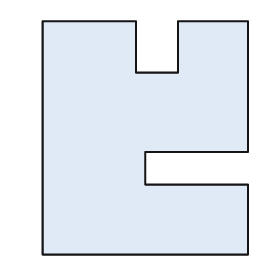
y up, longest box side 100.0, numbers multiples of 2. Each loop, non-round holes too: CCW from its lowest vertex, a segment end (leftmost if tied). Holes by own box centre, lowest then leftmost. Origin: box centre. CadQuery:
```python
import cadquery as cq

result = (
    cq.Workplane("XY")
    .moveTo(-44.0, -50.0)
    .lineTo(44.0, -50.0)
    .lineTo(44.0, -20.0)
    .lineTo(0.0, -20.0)
    .lineTo(0.0, -6.0)
    .lineTo(44.0, -6.0)
    .lineTo(44.0, 50.0)
    .lineTo(14.0, 50.0)
    .lineTo(14.0, 28.0)
    .lineTo(-4.0, 28.0)
    .lineTo(-4.0, 50.0)
    .lineTo(-44.0, 50.0)
    .close()
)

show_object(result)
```